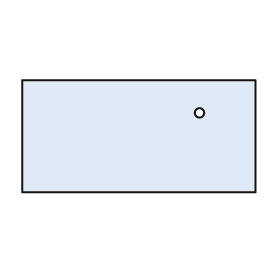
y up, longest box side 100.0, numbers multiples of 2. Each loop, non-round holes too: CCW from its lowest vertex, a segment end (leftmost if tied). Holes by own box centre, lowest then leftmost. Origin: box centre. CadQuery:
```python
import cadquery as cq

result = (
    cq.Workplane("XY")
    .moveTo(-50.0, -24.0)
    .lineTo(50.0, -24.0)
    .lineTo(50.0, 24.0)
    .lineTo(-50.0, 24.0)
    .close()
    .moveTo(26.0, 10.0)
    .circle(2.0)
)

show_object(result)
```